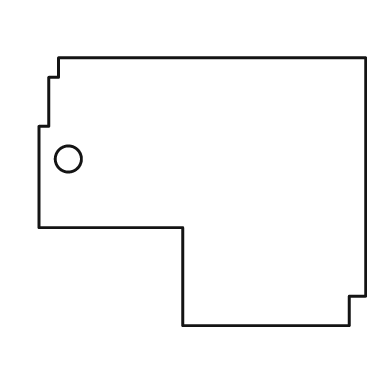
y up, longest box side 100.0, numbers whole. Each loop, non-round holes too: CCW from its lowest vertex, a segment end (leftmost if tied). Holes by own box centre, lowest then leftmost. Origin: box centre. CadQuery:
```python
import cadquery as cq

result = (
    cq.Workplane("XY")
    .moveTo(-6.0, -41.0)
    .lineTo(45.0, -41.0)
    .lineTo(45.0, -32.0)
    .lineTo(50.0, -32.0)
    .lineTo(50.0, 41.0)
    .lineTo(-44.0, 41.0)
    .lineTo(-44.0, 35.0)
    .lineTo(-47.0, 35.0)
    .lineTo(-47.0, 20.0)
    .lineTo(-50.0, 20.0)
    .lineTo(-50.0, -11.0)
    .lineTo(-6.0, -11.0)
    .close()
    .moveTo(-41.0, 10.0)
    .circle(4.0)
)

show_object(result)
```